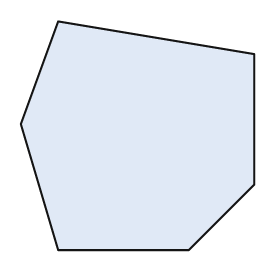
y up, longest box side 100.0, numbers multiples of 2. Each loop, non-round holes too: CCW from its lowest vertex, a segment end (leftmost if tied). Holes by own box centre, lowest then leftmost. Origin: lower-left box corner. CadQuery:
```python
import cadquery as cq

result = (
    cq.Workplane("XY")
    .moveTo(16.0, 0.0)
    .lineTo(72.0, 0.0)
    .lineTo(100.0, 28.0)
    .lineTo(100.0, 84.0)
    .lineTo(16.0, 98.0)
    .lineTo(0.0, 54.0)
    .close()
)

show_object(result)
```